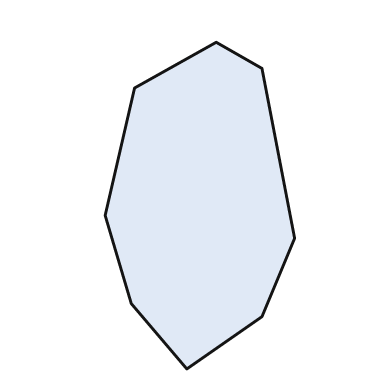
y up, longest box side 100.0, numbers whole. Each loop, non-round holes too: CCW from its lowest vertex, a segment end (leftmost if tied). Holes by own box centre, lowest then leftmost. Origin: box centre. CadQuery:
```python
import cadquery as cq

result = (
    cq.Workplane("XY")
    .moveTo(-4.0, -50.0)
    .lineTo(19.0, -34.0)
    .lineTo(29.0, -10.0)
    .lineTo(19.0, 42.0)
    .lineTo(5.0, 50.0)
    .lineTo(-20.0, 36.0)
    .lineTo(-29.0, -3.0)
    .lineTo(-21.0, -30.0)
    .close()
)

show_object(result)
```